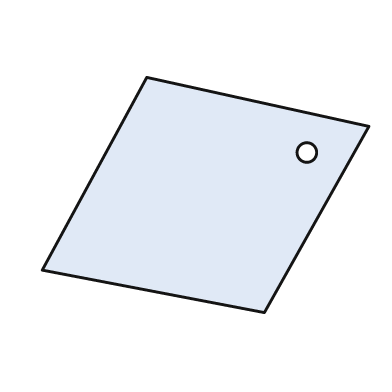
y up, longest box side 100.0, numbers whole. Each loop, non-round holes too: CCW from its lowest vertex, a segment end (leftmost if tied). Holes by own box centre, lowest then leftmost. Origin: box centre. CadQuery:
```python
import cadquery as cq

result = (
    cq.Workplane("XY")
    .moveTo(18.0, -36.0)
    .lineTo(50.0, 21.0)
    .lineTo(-18.0, 36.0)
    .lineTo(-50.0, -23.0)
    .close()
    .moveTo(31.0, 13.0)
    .circle(3.0)
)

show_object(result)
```